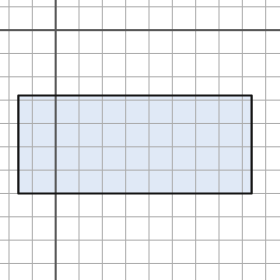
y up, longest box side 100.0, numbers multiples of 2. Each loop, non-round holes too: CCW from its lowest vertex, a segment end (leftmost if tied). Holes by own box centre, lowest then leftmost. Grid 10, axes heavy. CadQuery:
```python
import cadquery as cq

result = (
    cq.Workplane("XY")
    .moveTo(-16.0, -70.0)
    .lineTo(84.0, -70.0)
    .lineTo(84.0, -28.0)
    .lineTo(-16.0, -28.0)
    .close()
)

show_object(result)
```